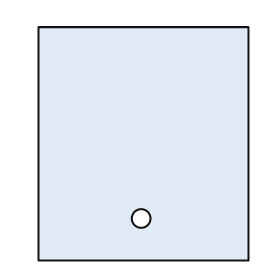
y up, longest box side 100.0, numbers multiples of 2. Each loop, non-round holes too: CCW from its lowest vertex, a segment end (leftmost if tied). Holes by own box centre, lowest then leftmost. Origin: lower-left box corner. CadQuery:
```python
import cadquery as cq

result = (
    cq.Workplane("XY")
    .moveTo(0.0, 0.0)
    .lineTo(90.0, 0.0)
    .lineTo(90.0, 100.0)
    .lineTo(0.0, 100.0)
    .close()
    .moveTo(44.0, 18.0)
    .circle(4.0)
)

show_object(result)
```